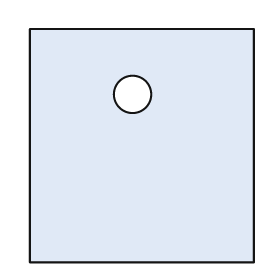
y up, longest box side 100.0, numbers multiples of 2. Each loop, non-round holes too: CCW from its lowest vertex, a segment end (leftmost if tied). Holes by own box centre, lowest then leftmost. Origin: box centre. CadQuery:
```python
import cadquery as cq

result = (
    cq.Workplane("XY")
    .moveTo(-48.0, -50.0)
    .lineTo(48.0, -50.0)
    .lineTo(48.0, 50.0)
    .lineTo(-48.0, 50.0)
    .close()
    .moveTo(-4.0, 22.0)
    .circle(8.0)
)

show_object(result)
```